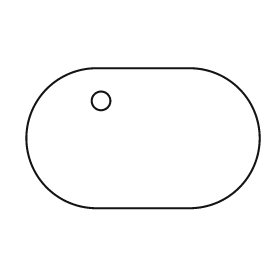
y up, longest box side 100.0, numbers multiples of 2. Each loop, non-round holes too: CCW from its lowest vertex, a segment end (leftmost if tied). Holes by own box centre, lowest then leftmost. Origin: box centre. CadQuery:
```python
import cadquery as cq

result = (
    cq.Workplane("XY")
    .moveTo(-20.0, -30.0)
    .lineTo(20.0, -30.0)
    .threePointArc((50.0, 0.0), (20.0, 30.0))
    .lineTo(-20.0, 30.0)
    .threePointArc((-50.0, 0.0), (-20.0, -30.0))
    .close()
    .moveTo(-18.0, 16.0)
    .circle(4.0)
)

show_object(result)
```